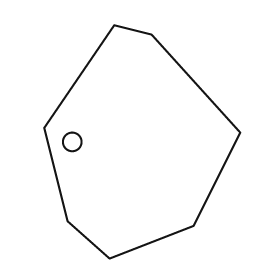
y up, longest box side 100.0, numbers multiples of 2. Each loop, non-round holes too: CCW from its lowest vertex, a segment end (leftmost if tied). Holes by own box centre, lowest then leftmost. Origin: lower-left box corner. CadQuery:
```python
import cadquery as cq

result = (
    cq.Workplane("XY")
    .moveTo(28.0, 0.0)
    .lineTo(64.0, 14.0)
    .lineTo(84.0, 54.0)
    .lineTo(46.0, 96.0)
    .lineTo(30.0, 100.0)
    .lineTo(0.0, 56.0)
    .lineTo(10.0, 16.0)
    .close()
    .moveTo(12.0, 50.0)
    .circle(4.0)
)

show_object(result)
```